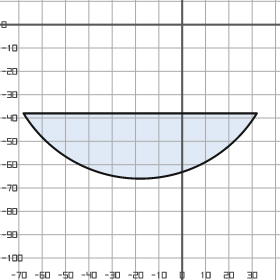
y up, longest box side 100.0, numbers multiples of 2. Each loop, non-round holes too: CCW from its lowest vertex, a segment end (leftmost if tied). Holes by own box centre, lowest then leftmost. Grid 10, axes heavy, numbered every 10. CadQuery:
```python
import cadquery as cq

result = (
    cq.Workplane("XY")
    .moveTo(-68.0, -38.0)
    .threePointArc((-18.0, -66.0), (32.0, -38.0))
    .close()
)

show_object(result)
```